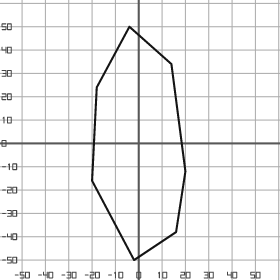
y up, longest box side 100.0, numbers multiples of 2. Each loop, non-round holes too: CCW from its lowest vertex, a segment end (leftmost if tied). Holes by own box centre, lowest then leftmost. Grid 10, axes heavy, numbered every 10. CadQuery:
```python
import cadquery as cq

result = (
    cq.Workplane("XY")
    .moveTo(-2.0, -50.0)
    .lineTo(16.0, -38.0)
    .lineTo(20.0, -12.0)
    .lineTo(14.0, 34.0)
    .lineTo(-4.0, 50.0)
    .lineTo(-18.0, 24.0)
    .lineTo(-20.0, -16.0)
    .close()
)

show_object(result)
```